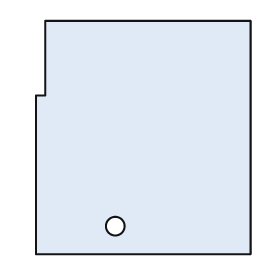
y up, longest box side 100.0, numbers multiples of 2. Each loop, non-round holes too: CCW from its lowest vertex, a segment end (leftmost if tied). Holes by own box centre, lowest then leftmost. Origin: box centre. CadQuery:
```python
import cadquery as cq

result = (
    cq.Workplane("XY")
    .moveTo(-46.0, -50.0)
    .lineTo(46.0, -50.0)
    .lineTo(46.0, 50.0)
    .lineTo(-42.0, 50.0)
    .lineTo(-42.0, 18.0)
    .lineTo(-46.0, 18.0)
    .close()
    .moveTo(-12.0, -38.0)
    .circle(4.0)
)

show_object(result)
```